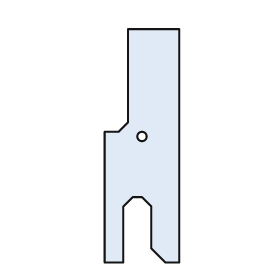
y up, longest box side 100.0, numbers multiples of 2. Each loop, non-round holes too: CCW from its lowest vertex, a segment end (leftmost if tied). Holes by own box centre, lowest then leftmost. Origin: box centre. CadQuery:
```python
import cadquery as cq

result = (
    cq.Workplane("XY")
    .moveTo(-16.0, -50.0)
    .lineTo(-8.0, -50.0)
    .lineTo(-8.0, -26.0)
    .lineTo(-4.0, -22.0)
    .lineTo(0.0, -22.0)
    .lineTo(4.0, -26.0)
    .lineTo(4.0, -44.0)
    .lineTo(10.0, -50.0)
    .lineTo(16.0, -50.0)
    .lineTo(16.0, 50.0)
    .lineTo(-6.0, 50.0)
    .lineTo(-6.0, 10.0)
    .lineTo(-10.0, 6.0)
    .lineTo(-16.0, 6.0)
    .close()
    .moveTo(0.0, 4.0)
    .circle(2.0)
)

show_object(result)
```